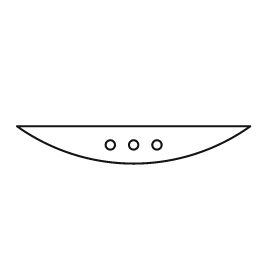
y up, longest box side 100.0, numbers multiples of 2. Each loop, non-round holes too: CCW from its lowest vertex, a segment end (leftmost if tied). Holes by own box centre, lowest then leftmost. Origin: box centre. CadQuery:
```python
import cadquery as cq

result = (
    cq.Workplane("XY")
    .moveTo(-50.0, 8.0)
    .threePointArc((0.0, -8.0), (50.0, 8.0))
    .close()
    .moveTo(-10.0, 0.0)
    .circle(2.0)
    .moveTo(0.0, 0.0)
    .circle(2.0)
    .moveTo(10.0, 0.0)
    .circle(2.0)
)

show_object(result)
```